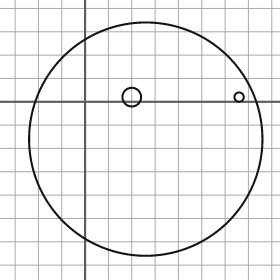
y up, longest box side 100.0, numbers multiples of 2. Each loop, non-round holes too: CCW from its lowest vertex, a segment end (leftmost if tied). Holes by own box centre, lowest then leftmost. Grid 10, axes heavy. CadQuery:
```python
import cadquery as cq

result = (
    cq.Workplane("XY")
    .moveTo(26.0, -16.0)
    .circle(50.0)
    .moveTo(20.0, 2.0)
    .circle(4.0)
    .moveTo(66.0, 2.0)
    .circle(2.0)
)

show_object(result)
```